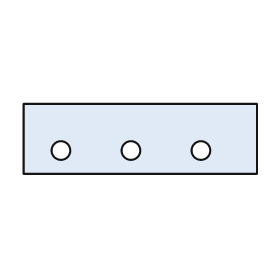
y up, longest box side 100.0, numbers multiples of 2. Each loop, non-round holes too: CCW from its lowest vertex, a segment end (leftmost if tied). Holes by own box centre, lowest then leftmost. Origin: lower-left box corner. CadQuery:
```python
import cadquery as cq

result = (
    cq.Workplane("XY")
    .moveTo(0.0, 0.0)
    .lineTo(100.0, 0.0)
    .lineTo(100.0, 30.0)
    .lineTo(0.0, 30.0)
    .close()
    .moveTo(16.0, 10.0)
    .circle(4.0)
    .moveTo(46.0, 10.0)
    .circle(4.0)
    .moveTo(76.0, 10.0)
    .circle(4.0)
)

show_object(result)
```